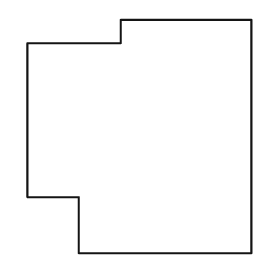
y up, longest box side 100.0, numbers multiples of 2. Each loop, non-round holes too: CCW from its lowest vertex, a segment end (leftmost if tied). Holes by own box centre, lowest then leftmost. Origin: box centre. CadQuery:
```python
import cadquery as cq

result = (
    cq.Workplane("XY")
    .moveTo(-26.0, -50.0)
    .lineTo(48.0, -50.0)
    .lineTo(48.0, 50.0)
    .lineTo(-8.0, 50.0)
    .lineTo(-8.0, 40.0)
    .lineTo(-48.0, 40.0)
    .lineTo(-48.0, -26.0)
    .lineTo(-26.0, -26.0)
    .close()
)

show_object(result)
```